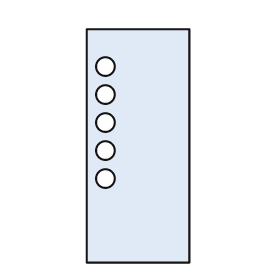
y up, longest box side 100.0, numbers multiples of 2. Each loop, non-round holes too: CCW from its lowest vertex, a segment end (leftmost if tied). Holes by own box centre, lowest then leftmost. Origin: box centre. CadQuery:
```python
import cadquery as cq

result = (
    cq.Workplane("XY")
    .moveTo(-22.0, -50.0)
    .lineTo(22.0, -50.0)
    .lineTo(22.0, 50.0)
    .lineTo(-22.0, 50.0)
    .close()
    .moveTo(-14.0, -14.0)
    .circle(4.0)
    .moveTo(-14.0, -2.0)
    .circle(4.0)
    .moveTo(-14.0, 10.0)
    .circle(4.0)
    .moveTo(-14.0, 22.0)
    .circle(4.0)
    .moveTo(-14.0, 34.0)
    .circle(4.0)
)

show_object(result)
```